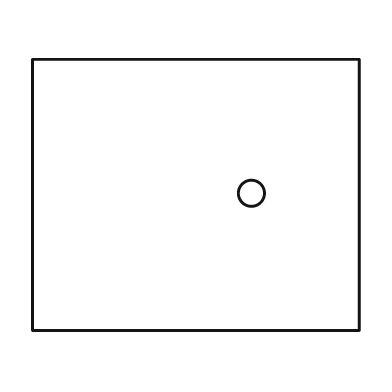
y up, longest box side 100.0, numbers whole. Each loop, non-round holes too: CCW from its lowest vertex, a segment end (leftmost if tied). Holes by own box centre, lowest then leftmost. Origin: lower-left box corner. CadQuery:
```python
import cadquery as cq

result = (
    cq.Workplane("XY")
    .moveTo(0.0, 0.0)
    .lineTo(100.0, 0.0)
    .lineTo(100.0, 83.0)
    .lineTo(0.0, 83.0)
    .close()
    .moveTo(67.0, 42.0)
    .circle(4.0)
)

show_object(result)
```